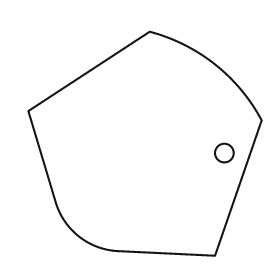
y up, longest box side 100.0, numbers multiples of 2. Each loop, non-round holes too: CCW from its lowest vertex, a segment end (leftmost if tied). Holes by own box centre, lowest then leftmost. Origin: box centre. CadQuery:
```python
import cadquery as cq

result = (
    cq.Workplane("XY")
    .moveTo(30.0, -48.0)
    .lineTo(50.0, 10.0)
    .threePointArc((30.0, 34.0), (2.0, 48.0))
    .lineTo(-50.0, 14.0)
    .lineTo(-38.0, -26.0)
    .threePointArc((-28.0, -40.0), (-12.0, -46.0))
    .close()
    .moveTo(34.0, -4.0)
    .circle(4.0)
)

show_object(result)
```